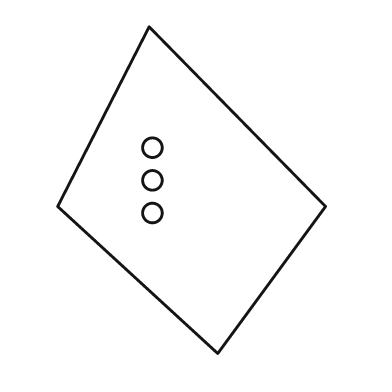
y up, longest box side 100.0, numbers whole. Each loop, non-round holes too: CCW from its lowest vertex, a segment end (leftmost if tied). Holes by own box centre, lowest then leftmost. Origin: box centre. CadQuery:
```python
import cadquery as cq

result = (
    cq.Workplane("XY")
    .moveTo(8.0, -50.0)
    .lineTo(41.0, -5.0)
    .lineTo(-13.0, 50.0)
    .lineTo(-41.0, -5.0)
    .close()
    .moveTo(-12.0, -7.0)
    .circle(3.0)
    .moveTo(-12.0, 3.0)
    .circle(3.0)
    .moveTo(-12.0, 13.0)
    .circle(3.0)
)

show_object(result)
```